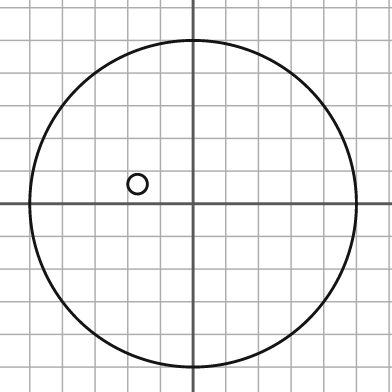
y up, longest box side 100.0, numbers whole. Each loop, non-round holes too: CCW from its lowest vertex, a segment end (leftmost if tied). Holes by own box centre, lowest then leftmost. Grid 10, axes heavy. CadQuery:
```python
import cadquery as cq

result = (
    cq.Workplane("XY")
    .moveTo(0.0, 0.0)
    .circle(50.0)
    .moveTo(-17.0, 6.0)
    .circle(3.0)
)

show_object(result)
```